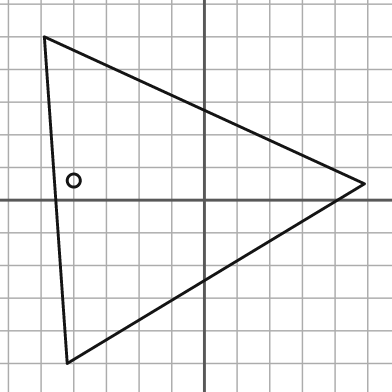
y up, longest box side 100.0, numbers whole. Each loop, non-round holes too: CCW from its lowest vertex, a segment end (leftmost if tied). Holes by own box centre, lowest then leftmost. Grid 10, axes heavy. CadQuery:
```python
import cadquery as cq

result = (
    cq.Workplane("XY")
    .moveTo(-42.0, -50.0)
    .lineTo(49.0, 5.0)
    .lineTo(-49.0, 50.0)
    .close()
    .moveTo(-40.0, 6.0)
    .circle(2.0)
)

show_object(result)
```